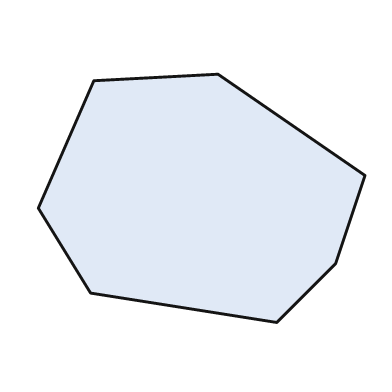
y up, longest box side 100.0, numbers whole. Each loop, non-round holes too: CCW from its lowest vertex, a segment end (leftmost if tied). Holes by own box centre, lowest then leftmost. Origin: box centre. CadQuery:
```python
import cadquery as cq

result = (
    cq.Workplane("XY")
    .moveTo(23.0, -38.0)
    .lineTo(41.0, -20.0)
    .lineTo(50.0, 7.0)
    .lineTo(5.0, 38.0)
    .lineTo(-33.0, 36.0)
    .lineTo(-50.0, -3.0)
    .lineTo(-34.0, -29.0)
    .close()
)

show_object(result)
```